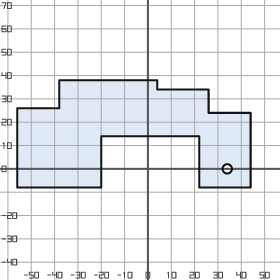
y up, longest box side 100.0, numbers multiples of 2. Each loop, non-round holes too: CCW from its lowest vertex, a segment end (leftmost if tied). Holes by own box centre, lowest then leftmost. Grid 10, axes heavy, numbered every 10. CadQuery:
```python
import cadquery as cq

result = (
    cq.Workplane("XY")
    .moveTo(-56.0, -8.0)
    .lineTo(-20.0, -8.0)
    .lineTo(-20.0, 14.0)
    .lineTo(22.0, 14.0)
    .lineTo(22.0, -8.0)
    .lineTo(44.0, -8.0)
    .lineTo(44.0, 24.0)
    .lineTo(26.0, 24.0)
    .lineTo(26.0, 34.0)
    .lineTo(4.0, 34.0)
    .lineTo(4.0, 38.0)
    .lineTo(-38.0, 38.0)
    .lineTo(-38.0, 26.0)
    .lineTo(-56.0, 26.0)
    .close()
    .moveTo(34.0, 0.0)
    .circle(2.0)
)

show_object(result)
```